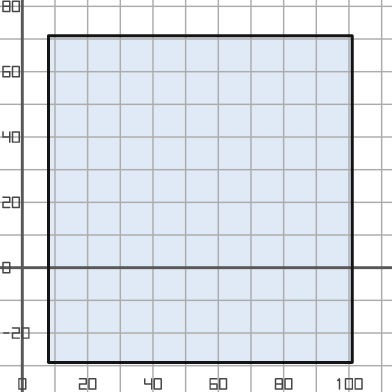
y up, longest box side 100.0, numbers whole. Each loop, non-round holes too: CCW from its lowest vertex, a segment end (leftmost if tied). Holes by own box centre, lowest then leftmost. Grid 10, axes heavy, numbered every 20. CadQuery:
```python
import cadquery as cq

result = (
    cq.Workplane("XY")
    .moveTo(8.0, -29.0)
    .lineTo(101.0, -29.0)
    .lineTo(101.0, 71.0)
    .lineTo(8.0, 71.0)
    .close()
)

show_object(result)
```